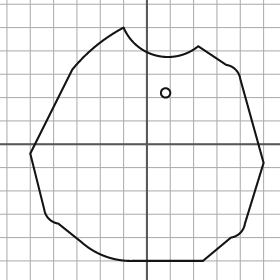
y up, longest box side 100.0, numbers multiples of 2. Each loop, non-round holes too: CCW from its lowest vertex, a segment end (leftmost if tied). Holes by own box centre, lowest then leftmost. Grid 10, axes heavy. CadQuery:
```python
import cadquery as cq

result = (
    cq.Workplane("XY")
    .moveTo(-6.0, -50.0)
    .lineTo(24.0, -50.0)
    .lineTo(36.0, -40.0)
    .threePointArc((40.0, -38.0), (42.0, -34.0))
    .lineTo(50.0, -8.0)
    .lineTo(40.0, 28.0)
    .threePointArc((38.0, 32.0), (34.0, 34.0))
    .lineTo(22.0, 42.0)
    .threePointArc((4.0, 38.0), (-10.0, 50.0))
    .threePointArc((-22.0, 42.0), (-32.0, 32.0))
    .lineTo(-50.0, -4.0)
    .lineTo(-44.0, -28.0)
    .threePointArc((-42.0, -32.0), (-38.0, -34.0))
    .lineTo(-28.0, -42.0)
    .threePointArc((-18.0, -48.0), (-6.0, -50.0))
    .close()
    .moveTo(8.0, 22.0)
    .circle(2.0)
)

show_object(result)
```